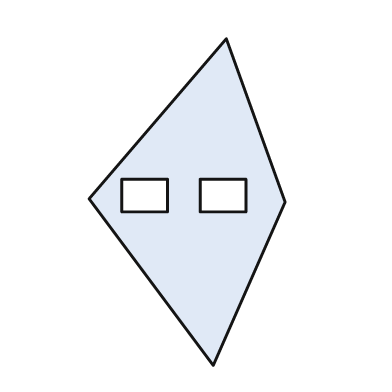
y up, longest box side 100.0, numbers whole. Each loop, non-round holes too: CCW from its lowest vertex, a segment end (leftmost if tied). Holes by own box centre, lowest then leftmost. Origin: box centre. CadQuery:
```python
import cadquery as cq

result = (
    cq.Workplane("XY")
    .moveTo(8.0, -50.0)
    .lineTo(30.0, 0.0)
    .lineTo(12.0, 50.0)
    .lineTo(-30.0, 1.0)
    .close()
    .moveTo(-20.0, -3.0)
    .lineTo(-6.0, -3.0)
    .lineTo(-6.0, 7.0)
    .lineTo(-20.0, 7.0)
    .close()
    .moveTo(4.0, -3.0)
    .lineTo(18.0, -3.0)
    .lineTo(18.0, 7.0)
    .lineTo(4.0, 7.0)
    .close()
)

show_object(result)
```